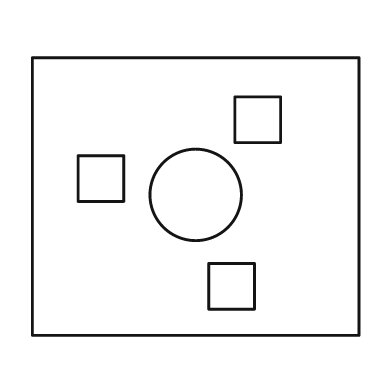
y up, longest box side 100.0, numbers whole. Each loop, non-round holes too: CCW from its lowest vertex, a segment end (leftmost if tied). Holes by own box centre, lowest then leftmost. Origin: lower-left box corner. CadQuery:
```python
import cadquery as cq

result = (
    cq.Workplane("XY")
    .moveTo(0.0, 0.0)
    .lineTo(100.0, 0.0)
    .lineTo(100.0, 85.0)
    .lineTo(0.0, 85.0)
    .close()
    .moveTo(54.0, 8.0)
    .lineTo(68.0, 8.0)
    .lineTo(68.0, 22.0)
    .lineTo(54.0, 22.0)
    .close()
    .moveTo(50.0, 43.0)
    .circle(14.0)
    .moveTo(14.0, 41.0)
    .lineTo(28.0, 41.0)
    .lineTo(28.0, 55.0)
    .lineTo(14.0, 55.0)
    .close()
    .moveTo(62.0, 59.0)
    .lineTo(76.0, 59.0)
    .lineTo(76.0, 73.0)
    .lineTo(62.0, 73.0)
    .close()
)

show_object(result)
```